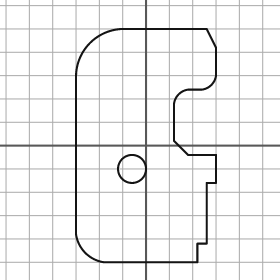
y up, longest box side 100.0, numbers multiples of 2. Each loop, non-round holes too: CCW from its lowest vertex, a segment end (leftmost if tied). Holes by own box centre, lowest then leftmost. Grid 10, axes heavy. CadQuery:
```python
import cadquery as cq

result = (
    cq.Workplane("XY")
    .moveTo(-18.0, -50.0)
    .lineTo(22.0, -50.0)
    .lineTo(22.0, -42.0)
    .lineTo(26.0, -42.0)
    .lineTo(26.0, -16.0)
    .lineTo(30.0, -16.0)
    .lineTo(30.0, -4.0)
    .lineTo(18.0, -4.0)
    .lineTo(12.0, 2.0)
    .lineTo(12.0, 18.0)
    .threePointArc((14.0, 22.0), (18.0, 24.0))
    .lineTo(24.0, 24.0)
    .threePointArc((28.0, 26.0), (30.0, 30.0))
    .lineTo(30.0, 42.0)
    .lineTo(26.0, 50.0)
    .lineTo(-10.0, 50.0)
    .threePointArc((-24.0, 44.0), (-30.0, 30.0))
    .lineTo(-30.0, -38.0)
    .threePointArc((-26.0, -46.0), (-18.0, -50.0))
    .close()
    .moveTo(-6.0, -10.0)
    .circle(6.0)
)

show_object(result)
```